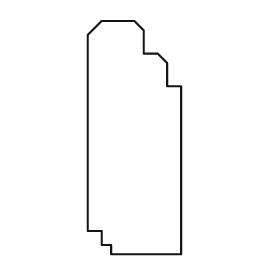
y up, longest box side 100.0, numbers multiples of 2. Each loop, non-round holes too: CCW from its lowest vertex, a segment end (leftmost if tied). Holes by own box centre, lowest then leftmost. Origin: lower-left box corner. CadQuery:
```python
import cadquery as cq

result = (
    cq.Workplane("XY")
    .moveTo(10.0, 0.0)
    .lineTo(40.0, 0.0)
    .lineTo(40.0, 72.0)
    .lineTo(34.0, 72.0)
    .lineTo(34.0, 82.0)
    .lineTo(30.0, 86.0)
    .lineTo(24.0, 86.0)
    .lineTo(24.0, 96.0)
    .lineTo(20.0, 100.0)
    .lineTo(6.0, 100.0)
    .lineTo(0.0, 94.0)
    .lineTo(0.0, 10.0)
    .lineTo(6.0, 10.0)
    .lineTo(6.0, 4.0)
    .lineTo(10.0, 4.0)
    .close()
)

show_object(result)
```